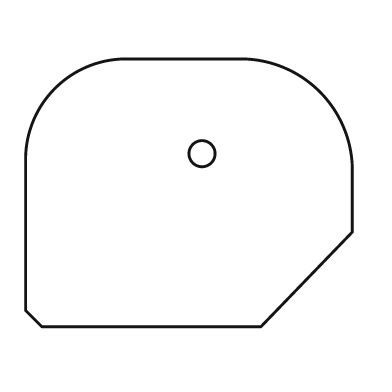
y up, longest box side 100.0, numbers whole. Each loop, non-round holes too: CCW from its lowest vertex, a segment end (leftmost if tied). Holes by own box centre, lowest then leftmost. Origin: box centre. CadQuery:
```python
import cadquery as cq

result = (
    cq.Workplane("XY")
    .moveTo(-45.0, -41.0)
    .lineTo(22.0, -41.0)
    .lineTo(50.0, -12.0)
    .lineTo(50.0, 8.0)
    .threePointArc((40.0, 31.0), (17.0, 41.0))
    .lineTo(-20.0, 41.0)
    .threePointArc((-41.0, 32.0), (-50.0, 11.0))
    .lineTo(-50.0, -36.0)
    .close()
    .moveTo(4.0, 12.0)
    .circle(4.0)
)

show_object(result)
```